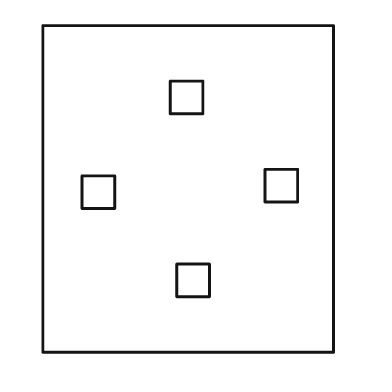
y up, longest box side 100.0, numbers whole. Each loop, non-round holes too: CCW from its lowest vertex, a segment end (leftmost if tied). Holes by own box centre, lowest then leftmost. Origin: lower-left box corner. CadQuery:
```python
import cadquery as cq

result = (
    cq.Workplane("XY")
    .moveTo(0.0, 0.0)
    .lineTo(89.0, 0.0)
    .lineTo(89.0, 100.0)
    .lineTo(0.0, 100.0)
    .close()
    .moveTo(41.0, 17.0)
    .lineTo(51.0, 17.0)
    .lineTo(51.0, 27.0)
    .lineTo(41.0, 27.0)
    .close()
    .moveTo(12.0, 44.0)
    .lineTo(22.0, 44.0)
    .lineTo(22.0, 54.0)
    .lineTo(12.0, 54.0)
    .close()
    .moveTo(68.0, 46.0)
    .lineTo(78.0, 46.0)
    .lineTo(78.0, 56.0)
    .lineTo(68.0, 56.0)
    .close()
    .moveTo(39.0, 73.0)
    .lineTo(49.0, 73.0)
    .lineTo(49.0, 83.0)
    .lineTo(39.0, 83.0)
    .close()
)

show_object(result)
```